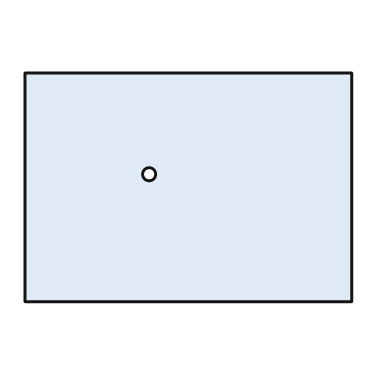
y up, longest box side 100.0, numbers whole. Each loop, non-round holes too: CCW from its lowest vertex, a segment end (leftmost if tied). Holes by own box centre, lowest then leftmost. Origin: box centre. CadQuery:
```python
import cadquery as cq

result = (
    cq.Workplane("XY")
    .moveTo(-50.0, -35.0)
    .lineTo(50.0, -35.0)
    .lineTo(50.0, 35.0)
    .lineTo(-50.0, 35.0)
    .close()
    .moveTo(-12.0, 4.0)
    .circle(2.0)
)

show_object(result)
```